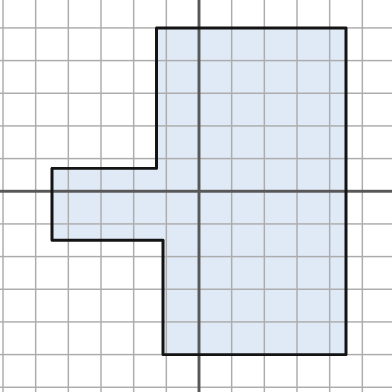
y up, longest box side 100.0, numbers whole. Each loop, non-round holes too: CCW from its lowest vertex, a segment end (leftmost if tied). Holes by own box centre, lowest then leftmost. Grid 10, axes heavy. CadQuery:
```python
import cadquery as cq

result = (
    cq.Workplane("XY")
    .moveTo(-11.0, -50.0)
    .lineTo(45.0, -50.0)
    .lineTo(45.0, 50.0)
    .lineTo(-13.0, 50.0)
    .lineTo(-13.0, 7.0)
    .lineTo(-45.0, 7.0)
    .lineTo(-45.0, -15.0)
    .lineTo(-11.0, -15.0)
    .close()
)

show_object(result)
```